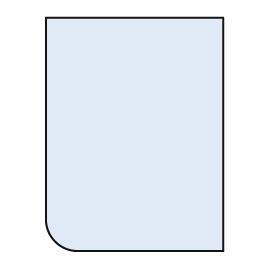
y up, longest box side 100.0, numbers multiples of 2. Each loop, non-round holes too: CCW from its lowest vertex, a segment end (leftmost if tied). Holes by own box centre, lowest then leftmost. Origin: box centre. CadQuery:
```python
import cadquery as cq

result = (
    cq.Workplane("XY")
    .moveTo(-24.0, -50.0)
    .lineTo(38.0, -50.0)
    .lineTo(38.0, 50.0)
    .lineTo(-38.0, 50.0)
    .lineTo(-38.0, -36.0)
    .threePointArc((-34.0, -46.0), (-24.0, -50.0))
    .close()
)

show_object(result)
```